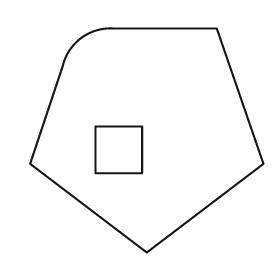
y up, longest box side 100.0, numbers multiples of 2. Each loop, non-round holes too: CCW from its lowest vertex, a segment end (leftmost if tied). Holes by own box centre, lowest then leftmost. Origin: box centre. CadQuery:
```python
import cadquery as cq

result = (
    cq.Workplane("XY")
    .moveTo(0.0, -48.0)
    .lineTo(50.0, -10.0)
    .lineTo(30.0, 48.0)
    .lineTo(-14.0, 48.0)
    .threePointArc((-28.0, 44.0), (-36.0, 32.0))
    .lineTo(-50.0, -10.0)
    .close()
    .moveTo(-22.0, -14.0)
    .lineTo(-2.0, -14.0)
    .lineTo(-2.0, 6.0)
    .lineTo(-22.0, 6.0)
    .close()
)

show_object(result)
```